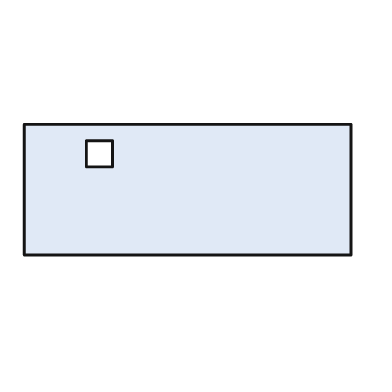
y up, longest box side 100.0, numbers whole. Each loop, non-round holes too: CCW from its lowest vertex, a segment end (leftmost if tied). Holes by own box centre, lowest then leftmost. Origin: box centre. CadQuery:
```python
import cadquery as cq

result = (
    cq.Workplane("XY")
    .moveTo(-50.0, -20.0)
    .lineTo(50.0, -20.0)
    .lineTo(50.0, 20.0)
    .lineTo(-50.0, 20.0)
    .close()
    .moveTo(-31.0, 7.0)
    .lineTo(-23.0, 7.0)
    .lineTo(-23.0, 15.0)
    .lineTo(-31.0, 15.0)
    .close()
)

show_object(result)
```